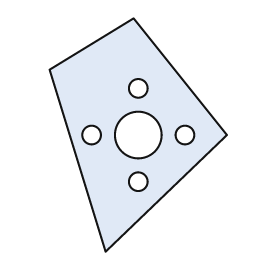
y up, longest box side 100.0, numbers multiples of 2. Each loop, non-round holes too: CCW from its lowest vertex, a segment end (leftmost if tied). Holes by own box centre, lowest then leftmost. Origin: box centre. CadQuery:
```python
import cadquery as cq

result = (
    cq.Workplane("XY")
    .moveTo(-14.0, -50.0)
    .lineTo(38.0, 0.0)
    .lineTo(-2.0, 50.0)
    .lineTo(-38.0, 28.0)
    .close()
    .moveTo(0.0, -20.0)
    .circle(4.0)
    .moveTo(-20.0, 0.0)
    .circle(4.0)
    .moveTo(0.0, 0.0)
    .circle(10.0)
    .moveTo(20.0, 0.0)
    .circle(4.0)
    .moveTo(0.0, 20.0)
    .circle(4.0)
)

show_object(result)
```